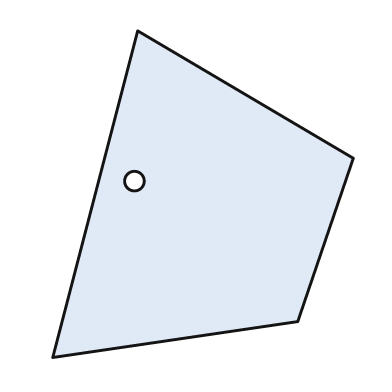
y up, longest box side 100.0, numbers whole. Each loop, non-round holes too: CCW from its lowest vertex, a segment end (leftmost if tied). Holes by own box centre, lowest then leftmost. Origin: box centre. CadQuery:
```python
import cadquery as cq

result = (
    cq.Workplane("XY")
    .moveTo(-46.0, -50.0)
    .lineTo(29.0, -39.0)
    .lineTo(46.0, 11.0)
    .lineTo(-20.0, 50.0)
    .close()
    .moveTo(-21.0, 4.0)
    .circle(3.0)
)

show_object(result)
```